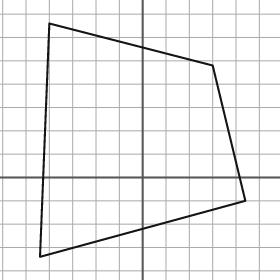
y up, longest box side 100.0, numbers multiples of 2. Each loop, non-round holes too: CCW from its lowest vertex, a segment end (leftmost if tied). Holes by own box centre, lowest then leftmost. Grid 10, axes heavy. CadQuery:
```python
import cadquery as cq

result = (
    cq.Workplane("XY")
    .moveTo(-44.0, -34.0)
    .lineTo(44.0, -10.0)
    .lineTo(30.0, 48.0)
    .lineTo(-40.0, 66.0)
    .close()
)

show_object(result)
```